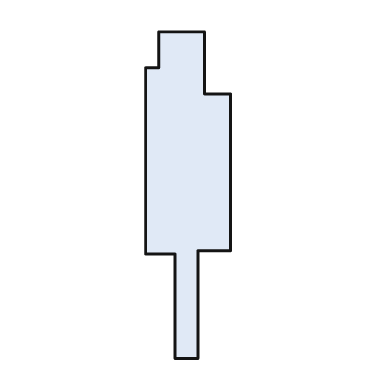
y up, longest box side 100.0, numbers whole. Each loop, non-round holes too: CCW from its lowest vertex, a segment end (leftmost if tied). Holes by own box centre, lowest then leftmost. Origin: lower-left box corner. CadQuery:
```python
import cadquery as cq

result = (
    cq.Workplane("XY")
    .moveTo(9.0, 0.0)
    .lineTo(16.0, 0.0)
    .lineTo(16.0, 33.0)
    .lineTo(26.0, 33.0)
    .lineTo(26.0, 81.0)
    .lineTo(18.0, 81.0)
    .lineTo(18.0, 100.0)
    .lineTo(4.0, 100.0)
    .lineTo(4.0, 89.0)
    .lineTo(0.0, 89.0)
    .lineTo(0.0, 32.0)
    .lineTo(9.0, 32.0)
    .close()
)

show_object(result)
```